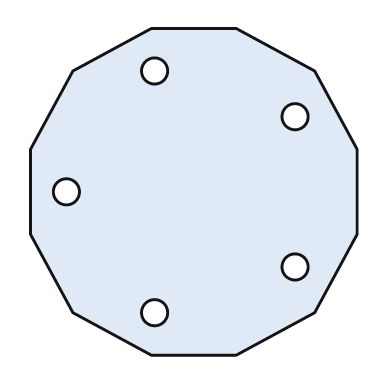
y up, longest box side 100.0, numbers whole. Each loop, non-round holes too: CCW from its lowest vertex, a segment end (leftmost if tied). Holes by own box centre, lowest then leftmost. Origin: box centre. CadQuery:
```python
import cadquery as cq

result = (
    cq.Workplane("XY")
    .moveTo(-13.0, -50.0)
    .lineTo(13.0, -50.0)
    .lineTo(37.0, -37.0)
    .lineTo(50.0, -13.0)
    .lineTo(50.0, 13.0)
    .lineTo(37.0, 37.0)
    .lineTo(13.0, 50.0)
    .lineTo(-13.0, 50.0)
    .lineTo(-37.0, 37.0)
    .lineTo(-50.0, 13.0)
    .lineTo(-50.0, -13.0)
    .lineTo(-37.0, -37.0)
    .close()
    .moveTo(-12.0, -37.0)
    .circle(4.0)
    .moveTo(31.0, -23.0)
    .circle(4.0)
    .moveTo(-39.0, 0.0)
    .circle(4.0)
    .moveTo(31.0, 23.0)
    .circle(4.0)
    .moveTo(-12.0, 37.0)
    .circle(4.0)
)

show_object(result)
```